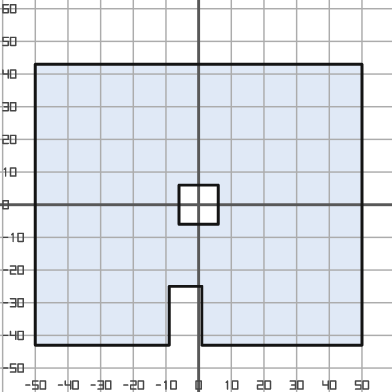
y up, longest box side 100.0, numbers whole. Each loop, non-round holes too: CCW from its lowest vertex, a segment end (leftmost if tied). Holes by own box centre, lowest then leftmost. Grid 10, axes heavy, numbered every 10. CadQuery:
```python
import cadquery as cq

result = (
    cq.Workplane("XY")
    .moveTo(-50.0, -43.0)
    .lineTo(-9.0, -43.0)
    .lineTo(-9.0, -25.0)
    .lineTo(1.0, -25.0)
    .lineTo(1.0, -43.0)
    .lineTo(50.0, -43.0)
    .lineTo(50.0, 43.0)
    .lineTo(-50.0, 43.0)
    .close()
    .moveTo(-6.0, -6.0)
    .lineTo(6.0, -6.0)
    .lineTo(6.0, 6.0)
    .lineTo(-6.0, 6.0)
    .close()
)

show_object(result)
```